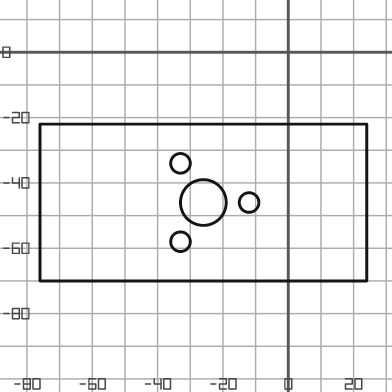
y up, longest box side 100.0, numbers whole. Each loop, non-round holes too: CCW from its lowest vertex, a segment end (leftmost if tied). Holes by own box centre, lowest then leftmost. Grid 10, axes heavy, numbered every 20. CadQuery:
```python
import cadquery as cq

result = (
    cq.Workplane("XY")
    .moveTo(-76.0, -70.0)
    .lineTo(24.0, -70.0)
    .lineTo(24.0, -22.0)
    .lineTo(-76.0, -22.0)
    .close()
    .moveTo(-33.0, -58.0)
    .circle(3.0)
    .moveTo(-26.0, -46.0)
    .circle(7.0)
    .moveTo(-12.0, -46.0)
    .circle(3.0)
    .moveTo(-33.0, -34.0)
    .circle(3.0)
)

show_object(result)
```